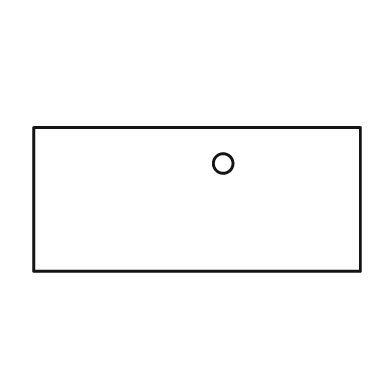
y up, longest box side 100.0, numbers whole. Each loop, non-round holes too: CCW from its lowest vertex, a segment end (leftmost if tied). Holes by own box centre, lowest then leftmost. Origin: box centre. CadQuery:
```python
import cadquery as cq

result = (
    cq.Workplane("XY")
    .moveTo(-50.0, -22.0)
    .lineTo(50.0, -22.0)
    .lineTo(50.0, 22.0)
    .lineTo(-50.0, 22.0)
    .close()
    .moveTo(8.0, 11.0)
    .circle(3.0)
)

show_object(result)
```